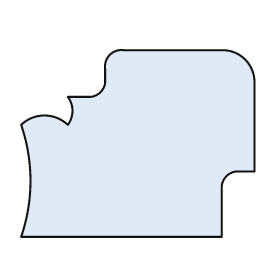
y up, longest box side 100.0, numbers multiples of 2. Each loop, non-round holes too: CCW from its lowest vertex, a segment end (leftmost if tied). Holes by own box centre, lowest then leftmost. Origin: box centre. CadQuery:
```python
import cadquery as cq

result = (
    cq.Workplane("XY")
    .moveTo(-50.0, -40.0)
    .lineTo(36.0, -40.0)
    .lineTo(36.0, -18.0)
    .threePointArc((38.0, -14.0), (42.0, -12.0))
    .lineTo(50.0, -12.0)
    .lineTo(50.0, 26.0)
    .threePointArc((46.0, 36.0), (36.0, 40.0))
    .lineTo(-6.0, 40.0)
    .threePointArc((-12.0, 38.0), (-14.0, 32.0))
    .lineTo(-14.0, 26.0)
    .threePointArc((-16.0, 22.0), (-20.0, 20.0))
    .lineTo(-30.0, 20.0)
    .threePointArc((-28.0, 14.0), (-30.0, 8.0))
    .threePointArc((-40.0, 12.0), (-50.0, 8.0))
    .threePointArc((-46.0, -16.0), (-50.0, -40.0))
    .close()
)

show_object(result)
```